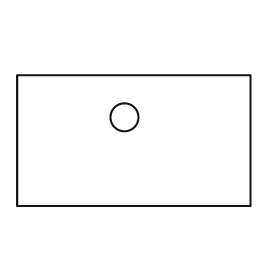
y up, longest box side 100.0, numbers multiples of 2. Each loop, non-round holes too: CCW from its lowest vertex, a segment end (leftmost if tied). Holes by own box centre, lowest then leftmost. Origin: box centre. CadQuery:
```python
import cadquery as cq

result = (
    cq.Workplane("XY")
    .moveTo(-50.0, -28.0)
    .lineTo(50.0, -28.0)
    .lineTo(50.0, 28.0)
    .lineTo(-50.0, 28.0)
    .close()
    .moveTo(-4.0, 10.0)
    .circle(6.0)
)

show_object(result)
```